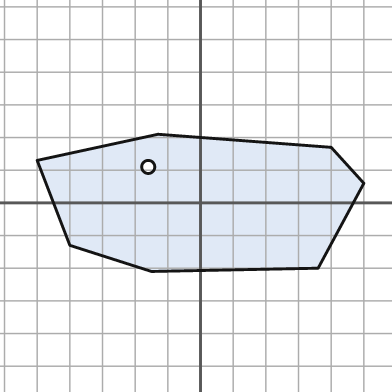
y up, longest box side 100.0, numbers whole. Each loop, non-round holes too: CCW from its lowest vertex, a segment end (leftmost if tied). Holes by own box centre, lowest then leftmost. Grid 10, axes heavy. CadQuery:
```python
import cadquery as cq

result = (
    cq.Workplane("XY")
    .moveTo(-15.0, -21.0)
    .lineTo(36.0, -20.0)
    .lineTo(50.0, 6.0)
    .lineTo(40.0, 17.0)
    .lineTo(-13.0, 21.0)
    .lineTo(-50.0, 13.0)
    .lineTo(-40.0, -13.0)
    .close()
    .moveTo(-16.0, 11.0)
    .circle(2.0)
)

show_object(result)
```